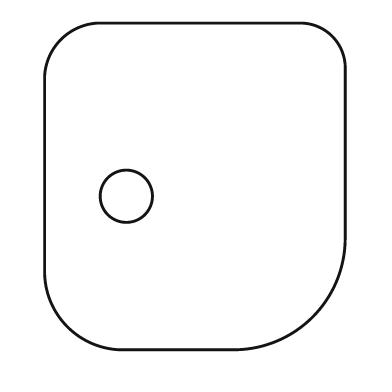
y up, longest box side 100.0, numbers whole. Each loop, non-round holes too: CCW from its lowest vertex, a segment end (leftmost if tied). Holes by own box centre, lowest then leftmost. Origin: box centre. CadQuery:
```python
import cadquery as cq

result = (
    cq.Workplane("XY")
    .moveTo(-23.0, -50.0)
    .lineTo(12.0, -50.0)
    .threePointArc((36.0, -40.0), (46.0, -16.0))
    .lineTo(46.0, 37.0)
    .threePointArc((42.0, 46.0), (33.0, 50.0))
    .lineTo(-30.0, 50.0)
    .threePointArc((-41.0, 45.0), (-46.0, 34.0))
    .lineTo(-46.0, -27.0)
    .threePointArc((-39.0, -43.0), (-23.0, -50.0))
    .close()
    .moveTo(-21.0, -3.0)
    .circle(8.0)
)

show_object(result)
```